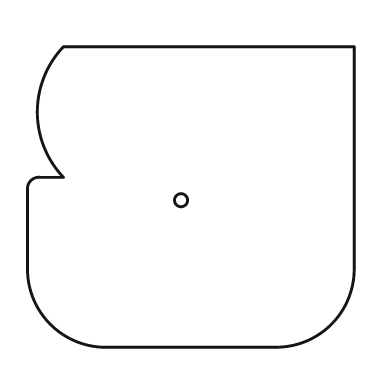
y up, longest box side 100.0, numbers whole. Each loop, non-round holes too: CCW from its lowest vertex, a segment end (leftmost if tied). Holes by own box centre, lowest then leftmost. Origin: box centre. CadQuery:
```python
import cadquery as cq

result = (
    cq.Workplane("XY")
    .moveTo(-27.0, -46.0)
    .lineTo(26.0, -46.0)
    .threePointArc((43.0, -39.0), (50.0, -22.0))
    .lineTo(50.0, 46.0)
    .lineTo(-39.0, 46.0)
    .threePointArc((-47.0, 26.0), (-39.0, 6.0))
    .lineTo(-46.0, 6.0)
    .threePointArc((-49.0, 5.0), (-50.0, 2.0))
    .lineTo(-50.0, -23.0)
    .threePointArc((-43.0, -39.0), (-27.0, -46.0))
    .close()
    .moveTo(-3.0, -1.0)
    .circle(2.0)
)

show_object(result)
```